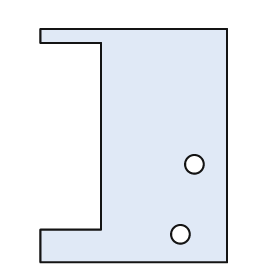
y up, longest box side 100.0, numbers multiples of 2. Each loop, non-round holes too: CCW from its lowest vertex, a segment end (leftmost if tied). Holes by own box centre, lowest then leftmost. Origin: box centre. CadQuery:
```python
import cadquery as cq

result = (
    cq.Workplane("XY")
    .moveTo(-40.0, -50.0)
    .lineTo(40.0, -50.0)
    .lineTo(40.0, 50.0)
    .lineTo(-40.0, 50.0)
    .lineTo(-40.0, 44.0)
    .lineTo(-14.0, 44.0)
    .lineTo(-14.0, -36.0)
    .lineTo(-40.0, -36.0)
    .close()
    .moveTo(20.0, -38.0)
    .circle(4.0)
    .moveTo(26.0, -8.0)
    .circle(4.0)
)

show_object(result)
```